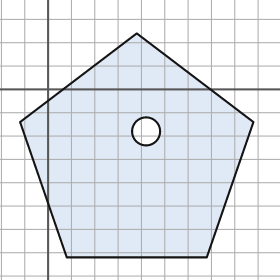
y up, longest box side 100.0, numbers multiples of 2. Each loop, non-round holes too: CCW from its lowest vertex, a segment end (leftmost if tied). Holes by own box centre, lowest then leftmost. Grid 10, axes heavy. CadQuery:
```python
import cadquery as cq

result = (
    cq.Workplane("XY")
    .moveTo(8.0, -72.0)
    .lineTo(68.0, -72.0)
    .lineTo(88.0, -14.0)
    .lineTo(38.0, 24.0)
    .lineTo(-12.0, -14.0)
    .close()
    .moveTo(42.0, -18.0)
    .circle(6.0)
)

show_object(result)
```